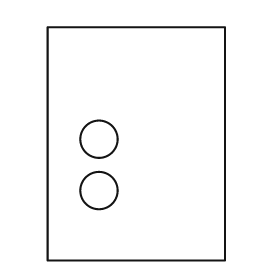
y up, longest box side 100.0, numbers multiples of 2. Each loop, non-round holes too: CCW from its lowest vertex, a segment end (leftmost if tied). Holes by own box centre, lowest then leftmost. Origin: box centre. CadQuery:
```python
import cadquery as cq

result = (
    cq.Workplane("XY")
    .moveTo(-38.0, -50.0)
    .lineTo(38.0, -50.0)
    .lineTo(38.0, 50.0)
    .lineTo(-38.0, 50.0)
    .close()
    .moveTo(-16.0, -20.0)
    .circle(8.0)
    .moveTo(-16.0, 2.0)
    .circle(8.0)
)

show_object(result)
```